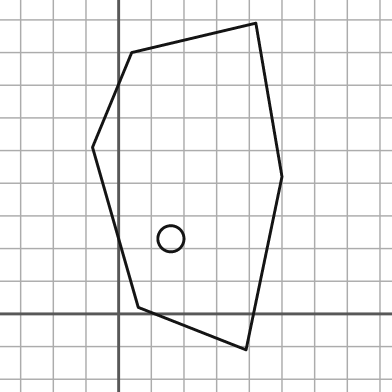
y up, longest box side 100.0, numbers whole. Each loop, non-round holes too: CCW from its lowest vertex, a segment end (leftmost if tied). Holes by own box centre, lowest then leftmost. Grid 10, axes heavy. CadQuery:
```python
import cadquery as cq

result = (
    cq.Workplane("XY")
    .moveTo(39.0, -11.0)
    .lineTo(50.0, 42.0)
    .lineTo(42.0, 89.0)
    .lineTo(4.0, 80.0)
    .lineTo(-8.0, 51.0)
    .lineTo(6.0, 2.0)
    .close()
    .moveTo(16.0, 23.0)
    .circle(4.0)
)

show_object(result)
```